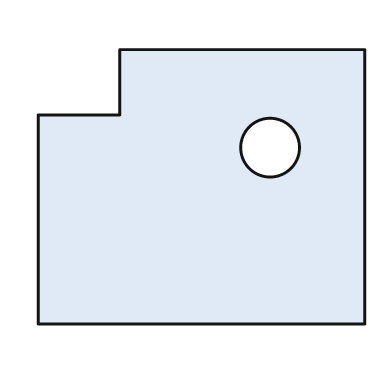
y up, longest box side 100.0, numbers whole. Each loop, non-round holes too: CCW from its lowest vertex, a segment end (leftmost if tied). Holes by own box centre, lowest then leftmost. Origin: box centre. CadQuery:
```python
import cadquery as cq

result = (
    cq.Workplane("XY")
    .moveTo(-50.0, -42.0)
    .lineTo(50.0, -42.0)
    .lineTo(50.0, 42.0)
    .lineTo(-25.0, 42.0)
    .lineTo(-25.0, 22.0)
    .lineTo(-50.0, 22.0)
    .close()
    .moveTo(21.0, 12.0)
    .circle(9.0)
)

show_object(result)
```